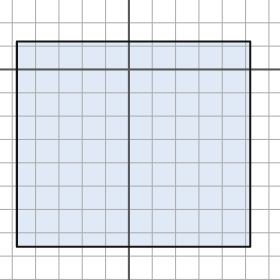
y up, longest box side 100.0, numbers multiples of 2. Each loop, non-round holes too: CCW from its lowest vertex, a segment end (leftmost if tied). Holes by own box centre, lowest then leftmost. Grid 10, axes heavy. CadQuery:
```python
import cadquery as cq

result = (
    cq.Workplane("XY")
    .moveTo(-48.0, -76.0)
    .lineTo(52.0, -76.0)
    .lineTo(52.0, 12.0)
    .lineTo(-48.0, 12.0)
    .close()
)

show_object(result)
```